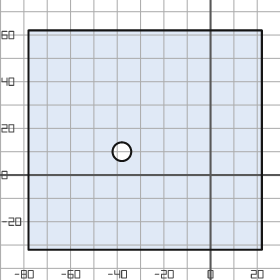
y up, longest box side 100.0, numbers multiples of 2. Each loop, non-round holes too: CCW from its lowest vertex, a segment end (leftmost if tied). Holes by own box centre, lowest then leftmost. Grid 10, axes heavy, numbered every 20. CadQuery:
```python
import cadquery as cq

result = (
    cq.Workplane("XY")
    .moveTo(-78.0, -32.0)
    .lineTo(22.0, -32.0)
    .lineTo(22.0, 62.0)
    .lineTo(-78.0, 62.0)
    .close()
    .moveTo(-38.0, 10.0)
    .circle(4.0)
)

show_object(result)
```